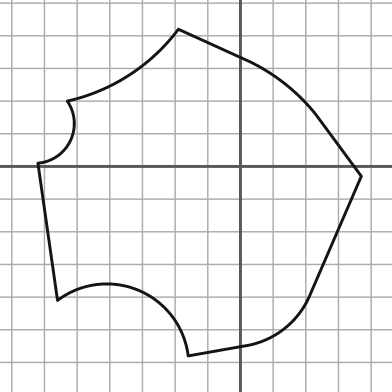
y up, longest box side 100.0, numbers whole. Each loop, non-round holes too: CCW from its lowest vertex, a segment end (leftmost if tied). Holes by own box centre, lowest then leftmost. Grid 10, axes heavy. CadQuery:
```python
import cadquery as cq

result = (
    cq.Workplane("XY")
    .moveTo(-16.0, -58.0)
    .lineTo(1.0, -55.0)
    .threePointArc((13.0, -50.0), (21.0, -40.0))
    .lineTo(37.0, -3.0)
    .lineTo(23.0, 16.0)
    .threePointArc((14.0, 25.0), (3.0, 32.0))
    .lineTo(-19.0, 42.0)
    .threePointArc((-34.0, 28.0), (-53.0, 20.0))
    .threePointArc((-52.0, 8.0), (-62.0, 1.0))
    .lineTo(-56.0, -41.0)
    .threePointArc((-31.0, -38.0), (-16.0, -58.0))
    .close()
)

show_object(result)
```